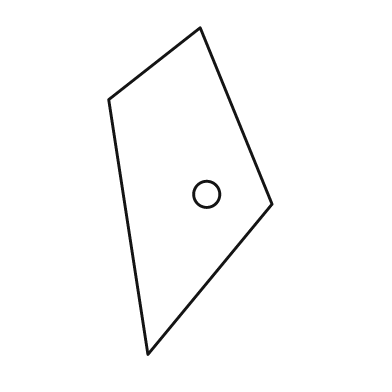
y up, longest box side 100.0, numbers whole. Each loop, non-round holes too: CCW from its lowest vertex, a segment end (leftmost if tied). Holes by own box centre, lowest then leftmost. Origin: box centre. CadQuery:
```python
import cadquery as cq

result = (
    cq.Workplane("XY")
    .moveTo(-13.0, -50.0)
    .lineTo(25.0, -4.0)
    .lineTo(3.0, 50.0)
    .lineTo(-25.0, 28.0)
    .close()
    .moveTo(5.0, -1.0)
    .circle(4.0)
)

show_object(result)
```